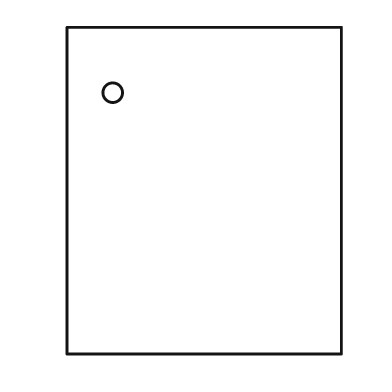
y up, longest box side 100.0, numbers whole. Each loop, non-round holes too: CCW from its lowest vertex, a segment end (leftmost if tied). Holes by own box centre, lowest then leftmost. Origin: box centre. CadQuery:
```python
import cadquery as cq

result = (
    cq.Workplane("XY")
    .moveTo(-42.0, -50.0)
    .lineTo(42.0, -50.0)
    .lineTo(42.0, 50.0)
    .lineTo(-42.0, 50.0)
    .close()
    .moveTo(-28.0, 30.0)
    .circle(3.0)
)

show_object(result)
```